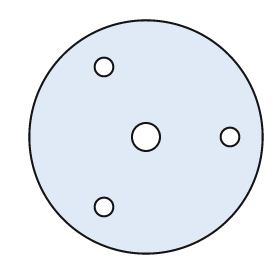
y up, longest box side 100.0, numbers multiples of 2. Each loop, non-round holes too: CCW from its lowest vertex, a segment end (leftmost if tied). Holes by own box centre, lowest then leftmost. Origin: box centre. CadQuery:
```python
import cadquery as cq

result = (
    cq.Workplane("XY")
    .moveTo(0.0, 0.0)
    .circle(50.0)
    .moveTo(-18.0, -30.0)
    .circle(4.0)
    .moveTo(0.0, 0.0)
    .circle(6.0)
    .moveTo(36.0, 0.0)
    .circle(4.0)
    .moveTo(-18.0, 30.0)
    .circle(4.0)
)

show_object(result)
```